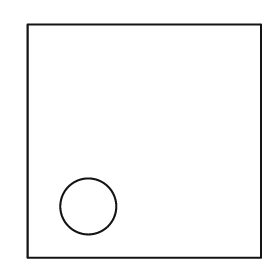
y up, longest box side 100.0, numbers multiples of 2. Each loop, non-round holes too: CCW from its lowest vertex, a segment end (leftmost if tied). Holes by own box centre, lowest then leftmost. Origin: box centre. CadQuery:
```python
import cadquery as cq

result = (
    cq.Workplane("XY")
    .moveTo(-50.0, -50.0)
    .lineTo(50.0, -50.0)
    .lineTo(50.0, 50.0)
    .lineTo(-50.0, 50.0)
    .close()
    .moveTo(-24.0, -28.0)
    .circle(12.0)
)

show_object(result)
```